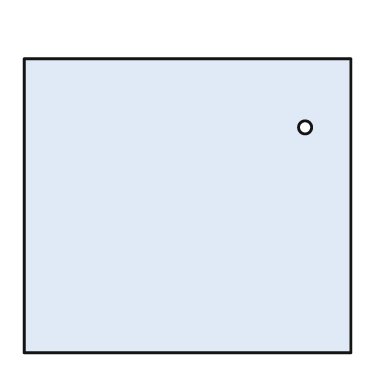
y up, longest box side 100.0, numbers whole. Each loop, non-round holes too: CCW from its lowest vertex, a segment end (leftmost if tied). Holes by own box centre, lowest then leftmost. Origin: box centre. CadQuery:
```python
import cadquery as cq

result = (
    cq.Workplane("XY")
    .moveTo(-50.0, -45.0)
    .lineTo(50.0, -45.0)
    .lineTo(50.0, 45.0)
    .lineTo(-50.0, 45.0)
    .close()
    .moveTo(36.0, 24.0)
    .circle(2.0)
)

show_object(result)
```